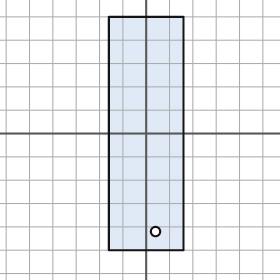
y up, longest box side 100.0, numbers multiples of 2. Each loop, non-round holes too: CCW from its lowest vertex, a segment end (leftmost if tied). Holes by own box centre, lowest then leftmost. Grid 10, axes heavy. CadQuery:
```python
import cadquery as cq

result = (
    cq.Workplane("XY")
    .moveTo(-16.0, -50.0)
    .lineTo(16.0, -50.0)
    .lineTo(16.0, 50.0)
    .lineTo(-16.0, 50.0)
    .close()
    .moveTo(4.0, -42.0)
    .circle(2.0)
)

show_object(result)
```